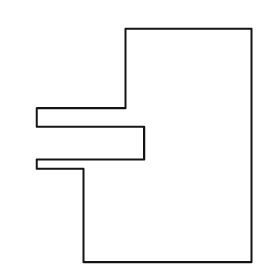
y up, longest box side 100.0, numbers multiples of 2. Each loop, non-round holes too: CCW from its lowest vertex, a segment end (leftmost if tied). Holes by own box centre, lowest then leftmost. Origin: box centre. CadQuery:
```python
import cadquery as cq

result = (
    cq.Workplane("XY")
    .moveTo(-26.0, -50.0)
    .lineTo(46.0, -50.0)
    .lineTo(46.0, 50.0)
    .lineTo(-8.0, 50.0)
    .lineTo(-8.0, 16.0)
    .lineTo(-46.0, 16.0)
    .lineTo(-46.0, 8.0)
    .lineTo(0.0, 8.0)
    .lineTo(0.0, -6.0)
    .lineTo(-46.0, -6.0)
    .lineTo(-46.0, -10.0)
    .lineTo(-26.0, -10.0)
    .close()
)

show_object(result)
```